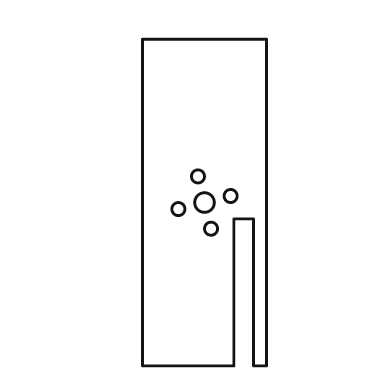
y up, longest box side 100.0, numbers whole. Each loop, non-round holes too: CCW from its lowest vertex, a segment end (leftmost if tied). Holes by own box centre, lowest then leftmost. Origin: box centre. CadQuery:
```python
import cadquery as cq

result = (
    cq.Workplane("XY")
    .moveTo(-19.0, -50.0)
    .lineTo(9.0, -50.0)
    .lineTo(9.0, -5.0)
    .lineTo(15.0, -5.0)
    .lineTo(15.0, -50.0)
    .lineTo(19.0, -50.0)
    .lineTo(19.0, 50.0)
    .lineTo(-19.0, 50.0)
    .close()
    .moveTo(2.0, -8.0)
    .circle(2.0)
    .moveTo(-8.0, -2.0)
    .circle(2.0)
    .moveTo(0.0, 0.0)
    .circle(3.0)
    .moveTo(8.0, 2.0)
    .circle(2.0)
    .moveTo(-2.0, 8.0)
    .circle(2.0)
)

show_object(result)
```